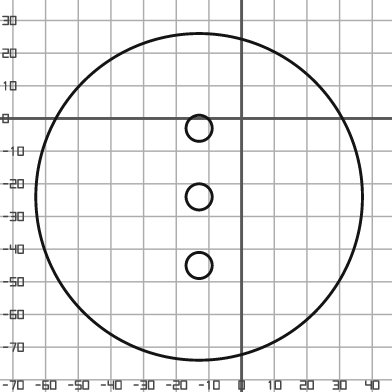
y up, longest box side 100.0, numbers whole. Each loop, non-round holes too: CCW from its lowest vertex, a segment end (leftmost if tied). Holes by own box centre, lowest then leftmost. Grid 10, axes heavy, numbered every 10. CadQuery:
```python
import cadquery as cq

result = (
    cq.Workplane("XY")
    .moveTo(-13.0, -24.0)
    .circle(50.0)
    .moveTo(-13.0, -45.0)
    .circle(4.0)
    .moveTo(-13.0, -24.0)
    .circle(4.0)
    .moveTo(-13.0, -3.0)
    .circle(4.0)
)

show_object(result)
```